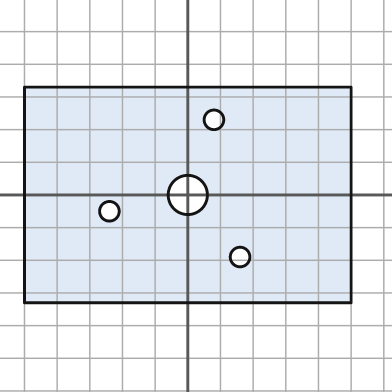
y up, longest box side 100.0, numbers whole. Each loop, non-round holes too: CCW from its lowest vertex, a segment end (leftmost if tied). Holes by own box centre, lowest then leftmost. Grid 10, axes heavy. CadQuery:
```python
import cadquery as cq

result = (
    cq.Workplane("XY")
    .moveTo(-50.0, -33.0)
    .lineTo(50.0, -33.0)
    .lineTo(50.0, 33.0)
    .lineTo(-50.0, 33.0)
    .close()
    .moveTo(16.0, -19.0)
    .circle(3.0)
    .moveTo(-24.0, -5.0)
    .circle(3.0)
    .moveTo(0.0, 0.0)
    .circle(6.0)
    .moveTo(8.0, 23.0)
    .circle(3.0)
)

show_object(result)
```